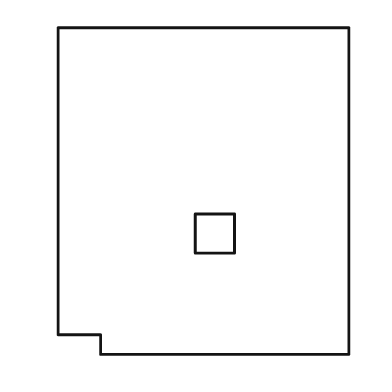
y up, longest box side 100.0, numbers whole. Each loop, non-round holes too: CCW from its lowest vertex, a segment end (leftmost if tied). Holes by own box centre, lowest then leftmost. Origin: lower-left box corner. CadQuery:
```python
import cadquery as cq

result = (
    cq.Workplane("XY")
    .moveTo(13.0, 0.0)
    .lineTo(89.0, 0.0)
    .lineTo(89.0, 100.0)
    .lineTo(0.0, 100.0)
    .lineTo(0.0, 6.0)
    .lineTo(13.0, 6.0)
    .close()
    .moveTo(42.0, 31.0)
    .lineTo(54.0, 31.0)
    .lineTo(54.0, 43.0)
    .lineTo(42.0, 43.0)
    .close()
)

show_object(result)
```